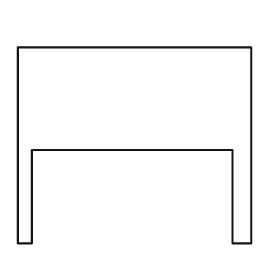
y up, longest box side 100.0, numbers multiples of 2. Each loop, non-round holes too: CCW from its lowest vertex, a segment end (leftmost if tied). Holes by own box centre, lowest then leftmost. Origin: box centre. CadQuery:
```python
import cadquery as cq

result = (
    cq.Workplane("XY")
    .moveTo(-50.0, -42.0)
    .lineTo(-44.0, -42.0)
    .lineTo(-44.0, -2.0)
    .lineTo(42.0, -2.0)
    .lineTo(42.0, -42.0)
    .lineTo(50.0, -42.0)
    .lineTo(50.0, 42.0)
    .lineTo(-50.0, 42.0)
    .close()
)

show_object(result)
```